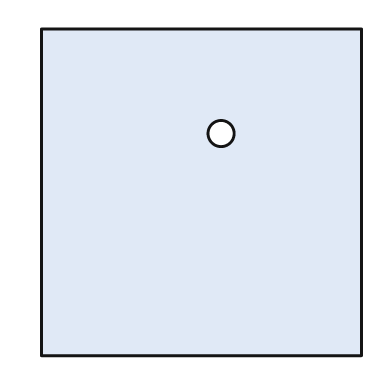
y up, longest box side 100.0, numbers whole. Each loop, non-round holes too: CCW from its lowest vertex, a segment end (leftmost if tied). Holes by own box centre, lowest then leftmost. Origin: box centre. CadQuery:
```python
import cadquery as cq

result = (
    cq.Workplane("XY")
    .moveTo(-49.0, -50.0)
    .lineTo(49.0, -50.0)
    .lineTo(49.0, 50.0)
    .lineTo(-49.0, 50.0)
    .close()
    .moveTo(6.0, 18.0)
    .circle(4.0)
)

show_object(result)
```